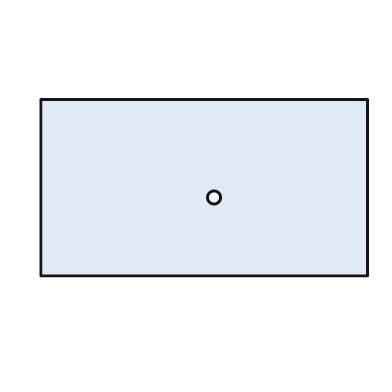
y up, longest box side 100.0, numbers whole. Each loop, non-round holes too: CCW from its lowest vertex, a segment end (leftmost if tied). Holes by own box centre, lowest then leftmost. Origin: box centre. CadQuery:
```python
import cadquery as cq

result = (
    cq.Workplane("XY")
    .moveTo(-50.0, -27.0)
    .lineTo(50.0, -27.0)
    .lineTo(50.0, 27.0)
    .lineTo(-50.0, 27.0)
    .close()
    .moveTo(3.0, -3.0)
    .circle(2.0)
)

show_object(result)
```